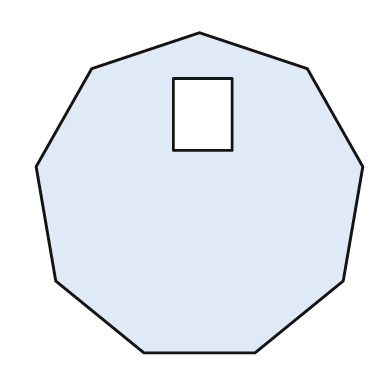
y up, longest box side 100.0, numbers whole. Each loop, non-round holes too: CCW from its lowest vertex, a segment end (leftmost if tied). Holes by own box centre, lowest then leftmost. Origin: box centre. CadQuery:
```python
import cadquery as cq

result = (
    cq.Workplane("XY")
    .moveTo(-17.0, -49.0)
    .lineTo(17.0, -49.0)
    .lineTo(44.0, -27.0)
    .lineTo(50.0, 8.0)
    .lineTo(33.0, 38.0)
    .lineTo(0.0, 49.0)
    .lineTo(-33.0, 38.0)
    .lineTo(-50.0, 8.0)
    .lineTo(-44.0, -27.0)
    .close()
    .moveTo(-8.0, 13.0)
    .lineTo(10.0, 13.0)
    .lineTo(10.0, 35.0)
    .lineTo(-8.0, 35.0)
    .close()
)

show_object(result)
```